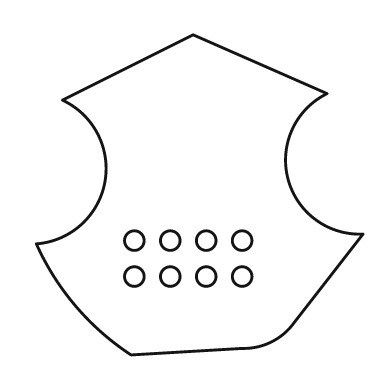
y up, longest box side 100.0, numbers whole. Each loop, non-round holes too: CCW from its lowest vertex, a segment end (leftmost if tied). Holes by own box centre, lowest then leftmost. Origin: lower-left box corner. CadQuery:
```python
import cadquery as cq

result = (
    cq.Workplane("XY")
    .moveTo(29.0, 0.0)
    .lineTo(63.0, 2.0)
    .threePointArc((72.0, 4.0), (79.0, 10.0))
    .lineTo(100.0, 37.0)
    .threePointArc((77.0, 54.0), (89.0, 80.0))
    .lineTo(48.0, 98.0)
    .lineTo(8.0, 78.0)
    .threePointArc((21.0, 53.0), (0.0, 34.0))
    .threePointArc((12.0, 15.0), (29.0, 0.0))
    .close()
    .moveTo(30.0, 24.0)
    .circle(3.0)
    .moveTo(41.0, 24.0)
    .circle(3.0)
    .moveTo(52.0, 24.0)
    .circle(3.0)
    .moveTo(63.0, 24.0)
    .circle(3.0)
    .moveTo(30.0, 35.0)
    .circle(3.0)
    .moveTo(41.0, 35.0)
    .circle(3.0)
    .moveTo(52.0, 35.0)
    .circle(3.0)
    .moveTo(63.0, 35.0)
    .circle(3.0)
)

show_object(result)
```